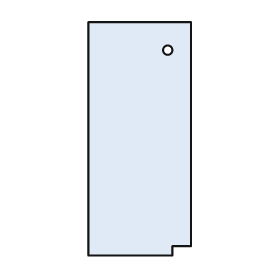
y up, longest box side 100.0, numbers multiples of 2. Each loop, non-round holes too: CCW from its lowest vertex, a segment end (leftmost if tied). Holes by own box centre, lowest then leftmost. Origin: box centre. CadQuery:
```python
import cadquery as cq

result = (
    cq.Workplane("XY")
    .moveTo(-22.0, -50.0)
    .lineTo(14.0, -50.0)
    .lineTo(14.0, -46.0)
    .lineTo(22.0, -46.0)
    .lineTo(22.0, 50.0)
    .lineTo(-22.0, 50.0)
    .close()
    .moveTo(12.0, 38.0)
    .circle(2.0)
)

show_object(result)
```